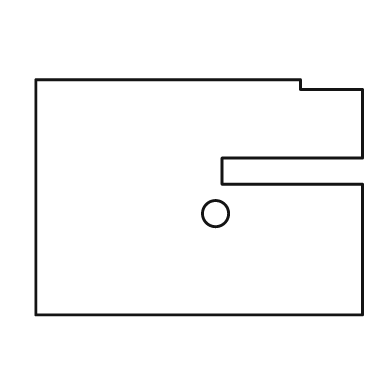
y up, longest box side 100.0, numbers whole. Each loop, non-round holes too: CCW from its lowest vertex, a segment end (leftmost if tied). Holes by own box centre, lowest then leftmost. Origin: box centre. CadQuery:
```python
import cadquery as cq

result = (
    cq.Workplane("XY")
    .moveTo(-50.0, -36.0)
    .lineTo(50.0, -36.0)
    .lineTo(50.0, 4.0)
    .lineTo(7.0, 4.0)
    .lineTo(7.0, 12.0)
    .lineTo(50.0, 12.0)
    .lineTo(50.0, 33.0)
    .lineTo(31.0, 33.0)
    .lineTo(31.0, 36.0)
    .lineTo(-50.0, 36.0)
    .close()
    .moveTo(5.0, -5.0)
    .circle(4.0)
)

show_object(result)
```